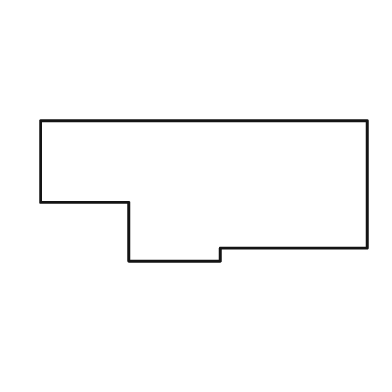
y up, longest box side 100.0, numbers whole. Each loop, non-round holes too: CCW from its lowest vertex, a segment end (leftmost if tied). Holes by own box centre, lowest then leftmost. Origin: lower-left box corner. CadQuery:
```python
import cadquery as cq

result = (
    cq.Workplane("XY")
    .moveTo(27.0, 0.0)
    .lineTo(55.0, 0.0)
    .lineTo(55.0, 4.0)
    .lineTo(100.0, 4.0)
    .lineTo(100.0, 43.0)
    .lineTo(0.0, 43.0)
    .lineTo(0.0, 18.0)
    .lineTo(27.0, 18.0)
    .close()
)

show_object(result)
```